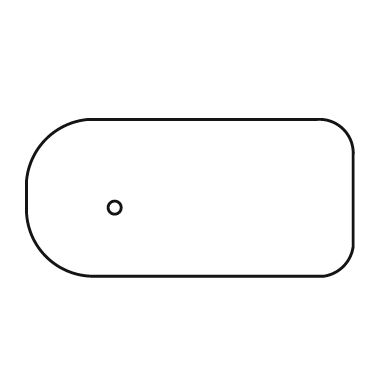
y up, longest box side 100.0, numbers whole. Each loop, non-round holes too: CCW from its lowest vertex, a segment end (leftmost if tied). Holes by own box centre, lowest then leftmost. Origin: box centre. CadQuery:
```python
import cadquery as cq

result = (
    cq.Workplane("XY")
    .moveTo(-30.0, -24.0)
    .lineTo(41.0, -24.0)
    .threePointArc((47.0, -21.0), (50.0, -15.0))
    .lineTo(50.0, 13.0)
    .threePointArc((47.0, 21.0), (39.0, 24.0))
    .lineTo(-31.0, 24.0)
    .threePointArc((-44.0, 18.0), (-50.0, 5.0))
    .lineTo(-50.0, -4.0)
    .threePointArc((-44.0, -18.0), (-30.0, -24.0))
    .close()
    .moveTo(-23.0, -3.0)
    .circle(2.0)
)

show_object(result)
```